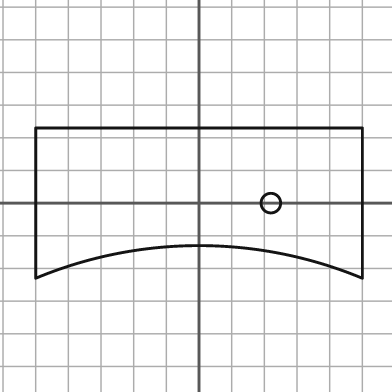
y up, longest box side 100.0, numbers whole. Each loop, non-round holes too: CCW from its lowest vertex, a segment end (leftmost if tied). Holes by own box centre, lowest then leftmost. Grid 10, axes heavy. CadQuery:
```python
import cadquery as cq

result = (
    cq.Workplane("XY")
    .moveTo(-50.0, -23.0)
    .threePointArc((0.0, -13.0), (50.0, -23.0))
    .lineTo(50.0, 23.0)
    .lineTo(-50.0, 23.0)
    .close()
    .moveTo(22.0, 0.0)
    .circle(3.0)
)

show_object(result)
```